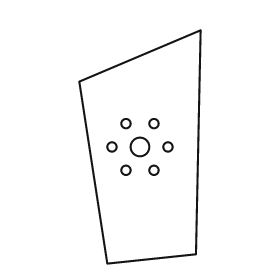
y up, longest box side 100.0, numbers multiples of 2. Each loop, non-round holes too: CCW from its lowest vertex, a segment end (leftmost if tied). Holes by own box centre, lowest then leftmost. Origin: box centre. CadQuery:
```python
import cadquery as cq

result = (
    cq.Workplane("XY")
    .moveTo(-14.0, -50.0)
    .lineTo(24.0, -46.0)
    .lineTo(26.0, 50.0)
    .lineTo(-26.0, 28.0)
    .close()
    .moveTo(-6.0, -10.0)
    .circle(2.0)
    .moveTo(6.0, -10.0)
    .circle(2.0)
    .moveTo(-12.0, 0.0)
    .circle(2.0)
    .moveTo(0.0, 0.0)
    .circle(4.0)
    .moveTo(12.0, 0.0)
    .circle(2.0)
    .moveTo(-6.0, 10.0)
    .circle(2.0)
    .moveTo(6.0, 10.0)
    .circle(2.0)
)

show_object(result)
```